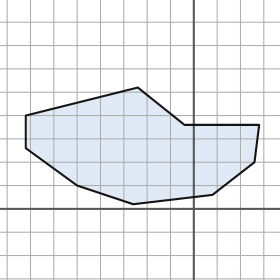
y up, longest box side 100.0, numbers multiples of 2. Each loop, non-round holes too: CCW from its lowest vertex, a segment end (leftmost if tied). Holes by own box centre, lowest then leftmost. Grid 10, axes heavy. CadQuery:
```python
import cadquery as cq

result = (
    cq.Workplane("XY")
    .moveTo(-26.0, 2.0)
    .lineTo(8.0, 6.0)
    .lineTo(26.0, 20.0)
    .lineTo(28.0, 36.0)
    .lineTo(-4.0, 36.0)
    .lineTo(-24.0, 52.0)
    .lineTo(-72.0, 40.0)
    .lineTo(-72.0, 26.0)
    .lineTo(-50.0, 10.0)
    .close()
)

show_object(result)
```